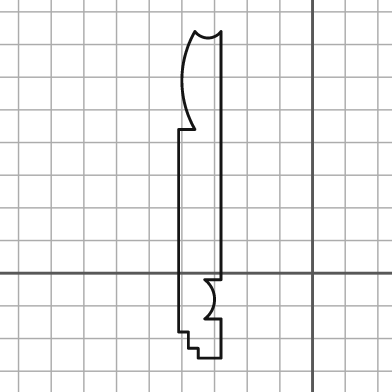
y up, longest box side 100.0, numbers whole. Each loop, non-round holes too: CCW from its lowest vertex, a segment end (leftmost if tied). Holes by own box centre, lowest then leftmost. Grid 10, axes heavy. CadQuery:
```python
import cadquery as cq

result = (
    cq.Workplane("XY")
    .moveTo(-35.0, -26.0)
    .lineTo(-28.0, -26.0)
    .lineTo(-28.0, -14.0)
    .lineTo(-33.0, -14.0)
    .threePointArc((-30.0, -8.0), (-33.0, -2.0))
    .lineTo(-28.0, -2.0)
    .lineTo(-28.0, 74.0)
    .threePointArc((-32.0, 72.0), (-36.0, 74.0))
    .threePointArc((-40.0, 59.0), (-36.0, 44.0))
    .lineTo(-41.0, 44.0)
    .lineTo(-41.0, -18.0)
    .lineTo(-38.0, -18.0)
    .lineTo(-38.0, -23.0)
    .lineTo(-35.0, -23.0)
    .close()
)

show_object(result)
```